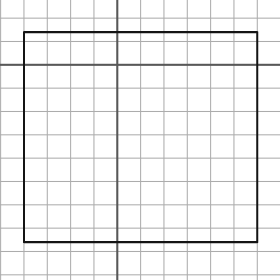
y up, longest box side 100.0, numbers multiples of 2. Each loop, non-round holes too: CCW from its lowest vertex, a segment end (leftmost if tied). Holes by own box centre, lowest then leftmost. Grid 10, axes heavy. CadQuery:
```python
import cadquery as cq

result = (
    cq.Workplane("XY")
    .moveTo(-40.0, -76.0)
    .lineTo(60.0, -76.0)
    .lineTo(60.0, 14.0)
    .lineTo(-40.0, 14.0)
    .close()
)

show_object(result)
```